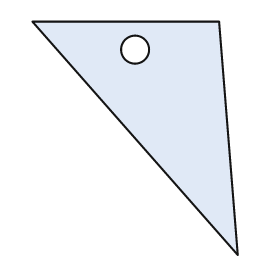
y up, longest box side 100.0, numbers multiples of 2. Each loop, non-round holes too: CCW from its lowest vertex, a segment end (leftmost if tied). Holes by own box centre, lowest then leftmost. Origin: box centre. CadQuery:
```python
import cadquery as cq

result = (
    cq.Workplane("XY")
    .moveTo(44.0, -50.0)
    .lineTo(36.0, 50.0)
    .lineTo(-44.0, 50.0)
    .close()
    .moveTo(0.0, 38.0)
    .circle(6.0)
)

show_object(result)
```